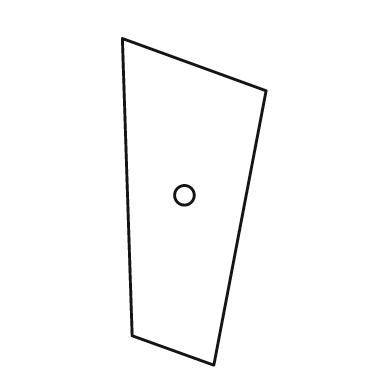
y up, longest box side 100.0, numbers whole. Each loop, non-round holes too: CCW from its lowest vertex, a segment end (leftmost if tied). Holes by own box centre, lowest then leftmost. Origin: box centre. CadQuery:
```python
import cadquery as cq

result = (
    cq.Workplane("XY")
    .moveTo(6.0, -50.0)
    .lineTo(22.0, 34.0)
    .lineTo(-22.0, 50.0)
    .lineTo(-19.0, -41.0)
    .close()
    .moveTo(-3.0, 2.0)
    .circle(3.0)
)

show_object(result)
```